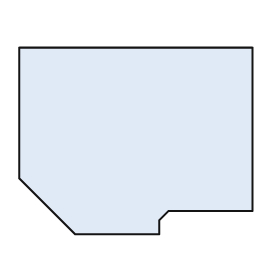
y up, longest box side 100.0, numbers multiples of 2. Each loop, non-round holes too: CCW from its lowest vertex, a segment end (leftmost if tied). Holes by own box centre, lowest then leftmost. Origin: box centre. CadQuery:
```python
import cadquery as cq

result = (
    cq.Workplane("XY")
    .moveTo(-26.0, -40.0)
    .lineTo(10.0, -40.0)
    .lineTo(10.0, -34.0)
    .lineTo(14.0, -30.0)
    .lineTo(50.0, -30.0)
    .lineTo(50.0, 40.0)
    .lineTo(-50.0, 40.0)
    .lineTo(-50.0, -16.0)
    .close()
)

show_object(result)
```